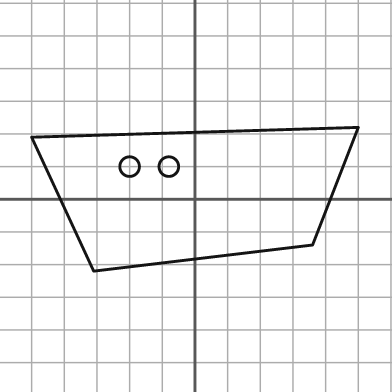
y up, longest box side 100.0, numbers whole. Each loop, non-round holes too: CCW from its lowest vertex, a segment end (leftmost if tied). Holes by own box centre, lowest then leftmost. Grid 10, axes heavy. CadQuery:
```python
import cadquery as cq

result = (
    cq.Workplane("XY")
    .moveTo(-31.0, -22.0)
    .lineTo(36.0, -14.0)
    .lineTo(50.0, 22.0)
    .lineTo(-50.0, 19.0)
    .close()
    .moveTo(-20.0, 10.0)
    .circle(3.0)
    .moveTo(-8.0, 10.0)
    .circle(3.0)
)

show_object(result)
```